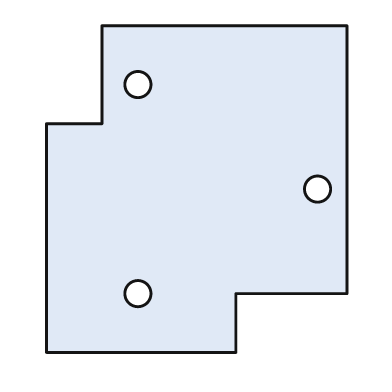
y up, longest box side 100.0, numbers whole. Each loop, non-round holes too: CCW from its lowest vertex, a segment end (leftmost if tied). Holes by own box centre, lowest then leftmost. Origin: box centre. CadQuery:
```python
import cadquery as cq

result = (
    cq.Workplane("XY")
    .moveTo(-46.0, -50.0)
    .lineTo(12.0, -50.0)
    .lineTo(12.0, -32.0)
    .lineTo(46.0, -32.0)
    .lineTo(46.0, 50.0)
    .lineTo(-29.0, 50.0)
    .lineTo(-29.0, 20.0)
    .lineTo(-46.0, 20.0)
    .close()
    .moveTo(-18.0, -32.0)
    .circle(4.0)
    .moveTo(37.0, 0.0)
    .circle(4.0)
    .moveTo(-18.0, 32.0)
    .circle(4.0)
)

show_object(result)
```